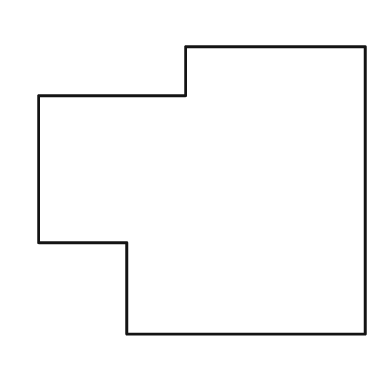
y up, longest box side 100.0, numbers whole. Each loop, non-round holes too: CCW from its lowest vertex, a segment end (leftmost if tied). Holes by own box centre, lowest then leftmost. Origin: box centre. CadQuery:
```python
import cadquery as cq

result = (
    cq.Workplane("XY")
    .moveTo(-23.0, -44.0)
    .lineTo(50.0, -44.0)
    .lineTo(50.0, 44.0)
    .lineTo(-5.0, 44.0)
    .lineTo(-5.0, 29.0)
    .lineTo(-50.0, 29.0)
    .lineTo(-50.0, -16.0)
    .lineTo(-23.0, -16.0)
    .close()
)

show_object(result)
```